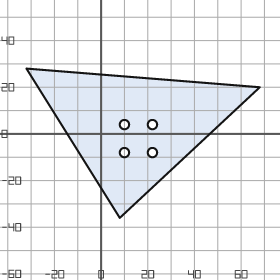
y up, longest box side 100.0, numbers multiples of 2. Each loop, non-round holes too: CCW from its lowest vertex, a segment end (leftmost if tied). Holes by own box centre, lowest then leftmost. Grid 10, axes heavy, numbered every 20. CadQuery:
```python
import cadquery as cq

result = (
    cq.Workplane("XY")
    .moveTo(8.0, -36.0)
    .lineTo(68.0, 20.0)
    .lineTo(-32.0, 28.0)
    .close()
    .moveTo(10.0, -8.0)
    .circle(2.0)
    .moveTo(22.0, -8.0)
    .circle(2.0)
    .moveTo(10.0, 4.0)
    .circle(2.0)
    .moveTo(22.0, 4.0)
    .circle(2.0)
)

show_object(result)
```